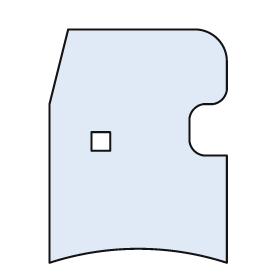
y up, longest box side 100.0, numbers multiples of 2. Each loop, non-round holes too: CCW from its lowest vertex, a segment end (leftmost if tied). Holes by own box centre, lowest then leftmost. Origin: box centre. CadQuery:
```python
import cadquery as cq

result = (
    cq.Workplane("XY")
    .moveTo(-38.0, -50.0)
    .threePointArc((0.0, -44.0), (38.0, -50.0))
    .lineTo(38.0, -4.0)
    .lineTo(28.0, -4.0)
    .threePointArc((24.0, -2.0), (22.0, 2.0))
    .lineTo(22.0, 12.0)
    .threePointArc((24.0, 16.0), (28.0, 18.0))
    .lineTo(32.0, 18.0)
    .threePointArc((36.0, 20.0), (38.0, 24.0))
    .lineTo(38.0, 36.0)
    .threePointArc((34.0, 46.0), (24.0, 50.0))
    .lineTo(-30.0, 50.0)
    .lineTo(-38.0, 18.0)
    .close()
    .moveTo(-20.0, -2.0)
    .lineTo(-12.0, -2.0)
    .lineTo(-12.0, 6.0)
    .lineTo(-20.0, 6.0)
    .close()
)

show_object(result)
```